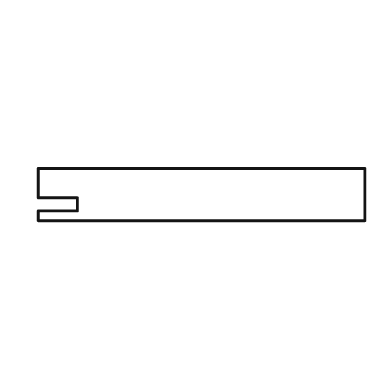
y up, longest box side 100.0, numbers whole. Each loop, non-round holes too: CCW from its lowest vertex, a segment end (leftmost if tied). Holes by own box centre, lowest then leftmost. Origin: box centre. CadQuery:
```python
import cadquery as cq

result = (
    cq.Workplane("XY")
    .moveTo(-50.0, -8.0)
    .lineTo(50.0, -8.0)
    .lineTo(50.0, 8.0)
    .lineTo(-50.0, 8.0)
    .lineTo(-50.0, -1.0)
    .lineTo(-38.0, -1.0)
    .lineTo(-38.0, -5.0)
    .lineTo(-50.0, -5.0)
    .close()
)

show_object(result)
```